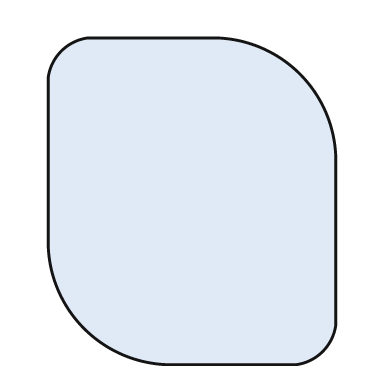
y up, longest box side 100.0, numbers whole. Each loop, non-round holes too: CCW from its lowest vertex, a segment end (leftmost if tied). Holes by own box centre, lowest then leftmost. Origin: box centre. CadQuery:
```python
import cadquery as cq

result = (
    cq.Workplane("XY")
    .moveTo(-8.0, -50.0)
    .lineTo(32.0, -50.0)
    .threePointArc((40.0, -46.0), (44.0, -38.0))
    .lineTo(44.0, 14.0)
    .threePointArc((33.0, 39.0), (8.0, 50.0))
    .lineTo(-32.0, 50.0)
    .threePointArc((-40.0, 46.0), (-44.0, 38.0))
    .lineTo(-44.0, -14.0)
    .threePointArc((-33.0, -39.0), (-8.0, -50.0))
    .close()
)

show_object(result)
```